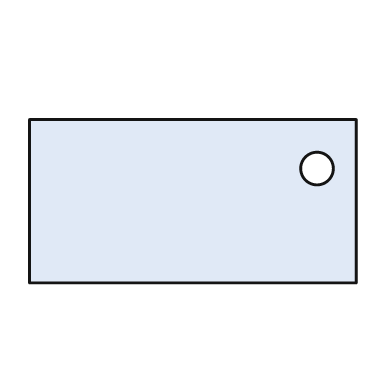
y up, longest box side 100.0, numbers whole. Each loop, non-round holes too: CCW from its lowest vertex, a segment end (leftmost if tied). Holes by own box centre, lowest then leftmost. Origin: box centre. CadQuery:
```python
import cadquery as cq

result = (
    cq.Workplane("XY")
    .moveTo(-50.0, -25.0)
    .lineTo(50.0, -25.0)
    .lineTo(50.0, 25.0)
    .lineTo(-50.0, 25.0)
    .close()
    .moveTo(38.0, 10.0)
    .circle(5.0)
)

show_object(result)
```